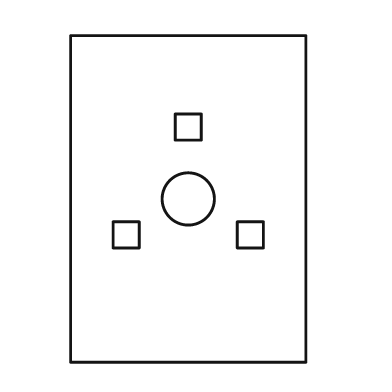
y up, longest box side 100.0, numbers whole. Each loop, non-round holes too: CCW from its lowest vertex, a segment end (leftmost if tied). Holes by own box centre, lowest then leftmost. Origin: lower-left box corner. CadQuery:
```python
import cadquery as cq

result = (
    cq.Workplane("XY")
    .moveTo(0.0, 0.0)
    .lineTo(72.0, 0.0)
    .lineTo(72.0, 100.0)
    .lineTo(0.0, 100.0)
    .close()
    .moveTo(13.0, 35.0)
    .lineTo(21.0, 35.0)
    .lineTo(21.0, 43.0)
    .lineTo(13.0, 43.0)
    .close()
    .moveTo(51.0, 35.0)
    .lineTo(59.0, 35.0)
    .lineTo(59.0, 43.0)
    .lineTo(51.0, 43.0)
    .close()
    .moveTo(36.0, 50.0)
    .circle(8.0)
    .moveTo(32.0, 68.0)
    .lineTo(40.0, 68.0)
    .lineTo(40.0, 76.0)
    .lineTo(32.0, 76.0)
    .close()
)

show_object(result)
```